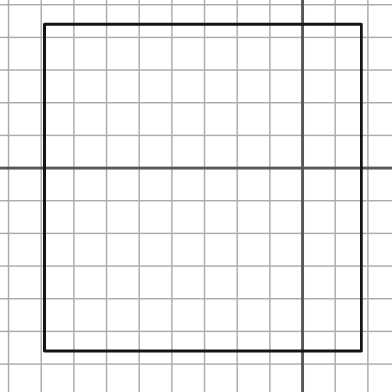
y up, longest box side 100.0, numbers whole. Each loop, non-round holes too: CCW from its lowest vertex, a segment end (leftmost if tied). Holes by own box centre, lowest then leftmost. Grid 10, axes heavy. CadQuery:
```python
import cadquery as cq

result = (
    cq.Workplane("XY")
    .moveTo(-79.0, -56.0)
    .lineTo(18.0, -56.0)
    .lineTo(18.0, 44.0)
    .lineTo(-79.0, 44.0)
    .close()
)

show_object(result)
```